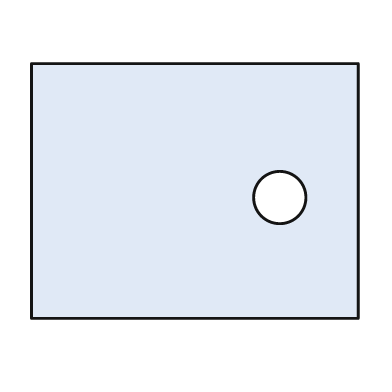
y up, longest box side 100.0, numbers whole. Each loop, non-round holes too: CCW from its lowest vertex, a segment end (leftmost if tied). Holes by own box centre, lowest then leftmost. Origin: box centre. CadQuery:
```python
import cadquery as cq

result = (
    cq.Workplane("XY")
    .moveTo(-50.0, -39.0)
    .lineTo(50.0, -39.0)
    .lineTo(50.0, 39.0)
    .lineTo(-50.0, 39.0)
    .close()
    .moveTo(26.0, -2.0)
    .circle(8.0)
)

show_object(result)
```